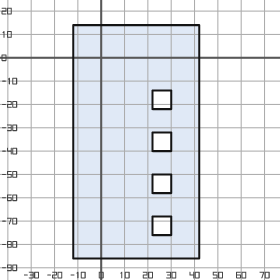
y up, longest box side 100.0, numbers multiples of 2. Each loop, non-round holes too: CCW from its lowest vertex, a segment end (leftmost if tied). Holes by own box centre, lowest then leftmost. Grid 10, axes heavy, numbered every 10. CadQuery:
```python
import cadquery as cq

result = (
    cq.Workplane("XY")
    .moveTo(-12.0, -86.0)
    .lineTo(42.0, -86.0)
    .lineTo(42.0, 14.0)
    .lineTo(-12.0, 14.0)
    .close()
    .moveTo(22.0, -76.0)
    .lineTo(30.0, -76.0)
    .lineTo(30.0, -68.0)
    .lineTo(22.0, -68.0)
    .close()
    .moveTo(22.0, -58.0)
    .lineTo(30.0, -58.0)
    .lineTo(30.0, -50.0)
    .lineTo(22.0, -50.0)
    .close()
    .moveTo(22.0, -40.0)
    .lineTo(30.0, -40.0)
    .lineTo(30.0, -32.0)
    .lineTo(22.0, -32.0)
    .close()
    .moveTo(22.0, -22.0)
    .lineTo(30.0, -22.0)
    .lineTo(30.0, -14.0)
    .lineTo(22.0, -14.0)
    .close()
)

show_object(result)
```